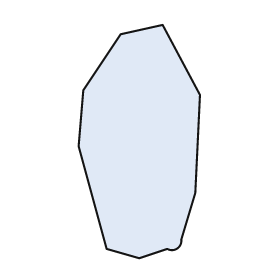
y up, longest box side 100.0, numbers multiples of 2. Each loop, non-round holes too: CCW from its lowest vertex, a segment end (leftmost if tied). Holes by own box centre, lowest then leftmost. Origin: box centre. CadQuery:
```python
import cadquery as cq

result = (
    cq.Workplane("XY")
    .moveTo(0.0, -50.0)
    .lineTo(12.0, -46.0)
    .threePointArc((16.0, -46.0), (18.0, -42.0))
    .lineTo(24.0, -22.0)
    .lineTo(26.0, 20.0)
    .lineTo(10.0, 50.0)
    .lineTo(-8.0, 46.0)
    .lineTo(-24.0, 22.0)
    .lineTo(-26.0, -2.0)
    .lineTo(-14.0, -46.0)
    .close()
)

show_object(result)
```